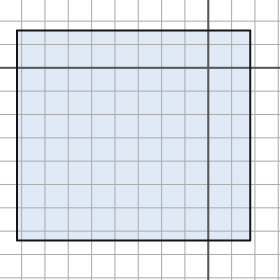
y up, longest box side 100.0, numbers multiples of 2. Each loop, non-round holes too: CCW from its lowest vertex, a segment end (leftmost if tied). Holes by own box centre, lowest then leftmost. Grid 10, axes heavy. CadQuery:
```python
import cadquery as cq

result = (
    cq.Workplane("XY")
    .moveTo(-82.0, -74.0)
    .lineTo(18.0, -74.0)
    .lineTo(18.0, 16.0)
    .lineTo(-82.0, 16.0)
    .close()
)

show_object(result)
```